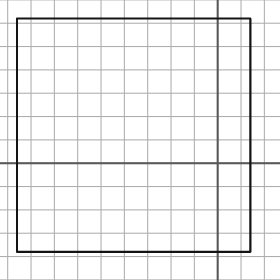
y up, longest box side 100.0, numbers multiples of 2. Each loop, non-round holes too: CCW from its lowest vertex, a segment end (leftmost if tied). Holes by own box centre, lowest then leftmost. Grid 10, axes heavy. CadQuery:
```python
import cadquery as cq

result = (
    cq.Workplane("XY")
    .moveTo(-86.0, -38.0)
    .lineTo(14.0, -38.0)
    .lineTo(14.0, 62.0)
    .lineTo(-86.0, 62.0)
    .close()
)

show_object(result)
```